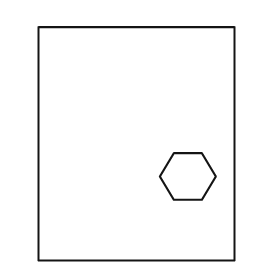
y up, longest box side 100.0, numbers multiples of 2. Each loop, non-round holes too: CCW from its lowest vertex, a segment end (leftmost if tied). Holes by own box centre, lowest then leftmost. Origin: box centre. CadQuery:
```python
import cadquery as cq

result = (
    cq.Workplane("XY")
    .moveTo(-42.0, -50.0)
    .lineTo(42.0, -50.0)
    .lineTo(42.0, 50.0)
    .lineTo(-42.0, 50.0)
    .close()
    .moveTo(16.0, -24.0)
    .lineTo(28.0, -24.0)
    .lineTo(34.0, -14.0)
    .lineTo(28.0, -4.0)
    .lineTo(16.0, -4.0)
    .lineTo(10.0, -14.0)
    .close()
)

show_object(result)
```